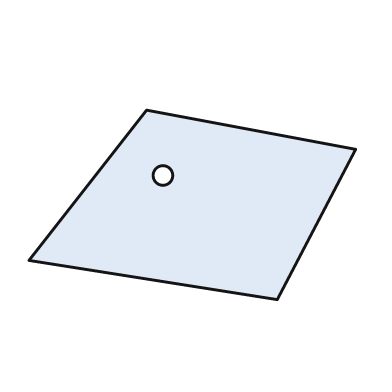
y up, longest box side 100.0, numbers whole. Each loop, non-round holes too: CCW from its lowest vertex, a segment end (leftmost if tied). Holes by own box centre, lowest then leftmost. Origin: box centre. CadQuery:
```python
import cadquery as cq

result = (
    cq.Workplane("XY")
    .moveTo(26.0, -29.0)
    .lineTo(50.0, 17.0)
    .lineTo(-14.0, 29.0)
    .lineTo(-50.0, -17.0)
    .close()
    .moveTo(-9.0, 9.0)
    .circle(3.0)
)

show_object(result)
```